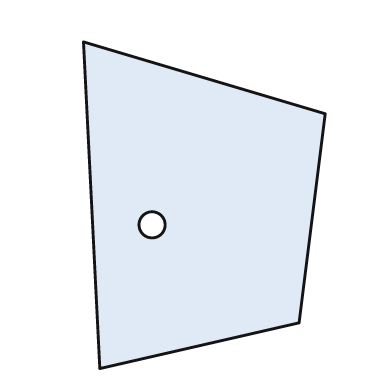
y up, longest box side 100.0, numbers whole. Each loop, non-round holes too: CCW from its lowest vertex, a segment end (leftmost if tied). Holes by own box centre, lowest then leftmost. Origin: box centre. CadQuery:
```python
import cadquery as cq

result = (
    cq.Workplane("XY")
    .moveTo(-32.0, -50.0)
    .lineTo(29.0, -36.0)
    .lineTo(37.0, 28.0)
    .lineTo(-37.0, 50.0)
    .close()
    .moveTo(-16.0, -6.0)
    .circle(4.0)
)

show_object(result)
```